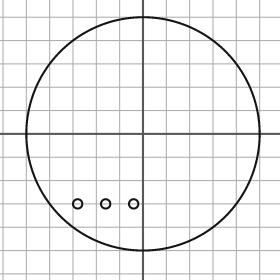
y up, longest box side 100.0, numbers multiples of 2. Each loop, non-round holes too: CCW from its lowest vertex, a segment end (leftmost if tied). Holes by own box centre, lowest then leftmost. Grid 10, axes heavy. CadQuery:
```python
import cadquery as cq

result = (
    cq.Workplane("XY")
    .moveTo(0.0, 0.0)
    .circle(50.0)
    .moveTo(-28.0, -30.0)
    .circle(2.0)
    .moveTo(-16.0, -30.0)
    .circle(2.0)
    .moveTo(-4.0, -30.0)
    .circle(2.0)
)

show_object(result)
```